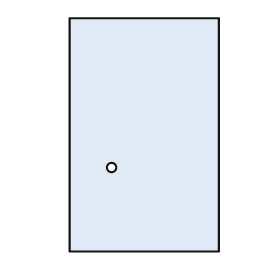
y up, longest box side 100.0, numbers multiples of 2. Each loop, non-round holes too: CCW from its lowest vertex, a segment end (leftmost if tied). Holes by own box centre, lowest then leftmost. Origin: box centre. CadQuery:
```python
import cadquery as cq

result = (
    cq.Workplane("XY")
    .moveTo(-32.0, -50.0)
    .lineTo(32.0, -50.0)
    .lineTo(32.0, 50.0)
    .lineTo(-32.0, 50.0)
    .close()
    .moveTo(-14.0, -14.0)
    .circle(2.0)
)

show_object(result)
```